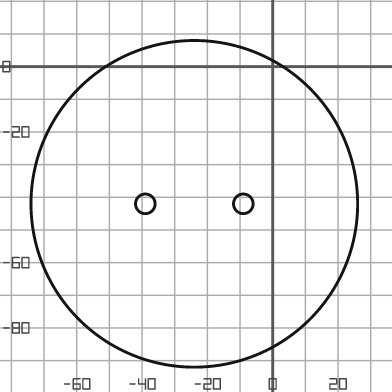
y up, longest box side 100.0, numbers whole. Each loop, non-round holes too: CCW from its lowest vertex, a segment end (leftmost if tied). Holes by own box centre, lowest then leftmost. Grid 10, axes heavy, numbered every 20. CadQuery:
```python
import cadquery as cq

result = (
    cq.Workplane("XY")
    .moveTo(-24.0, -42.0)
    .circle(50.0)
    .moveTo(-39.0, -42.0)
    .circle(3.0)
    .moveTo(-9.0, -42.0)
    .circle(3.0)
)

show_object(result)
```